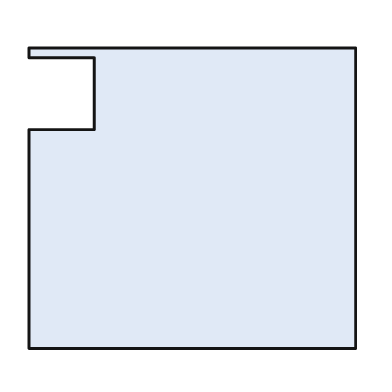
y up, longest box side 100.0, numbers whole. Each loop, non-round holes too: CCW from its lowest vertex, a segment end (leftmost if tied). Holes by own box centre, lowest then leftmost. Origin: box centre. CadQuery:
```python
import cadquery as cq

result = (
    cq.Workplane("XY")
    .moveTo(-50.0, -46.0)
    .lineTo(50.0, -46.0)
    .lineTo(50.0, 46.0)
    .lineTo(-50.0, 46.0)
    .lineTo(-50.0, 43.0)
    .lineTo(-30.0, 43.0)
    .lineTo(-30.0, 21.0)
    .lineTo(-50.0, 21.0)
    .close()
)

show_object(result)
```